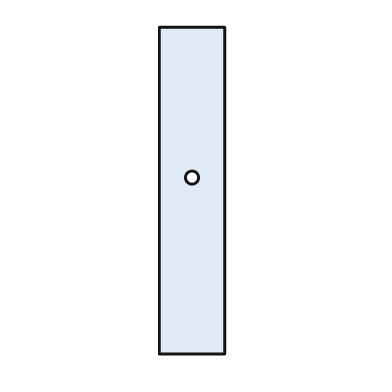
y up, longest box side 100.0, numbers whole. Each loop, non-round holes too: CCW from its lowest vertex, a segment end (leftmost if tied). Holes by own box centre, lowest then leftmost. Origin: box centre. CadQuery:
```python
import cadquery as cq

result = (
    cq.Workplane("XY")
    .moveTo(-10.0, -50.0)
    .lineTo(10.0, -50.0)
    .lineTo(10.0, 50.0)
    .lineTo(-10.0, 50.0)
    .close()
    .moveTo(0.0, 4.0)
    .circle(2.0)
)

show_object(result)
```